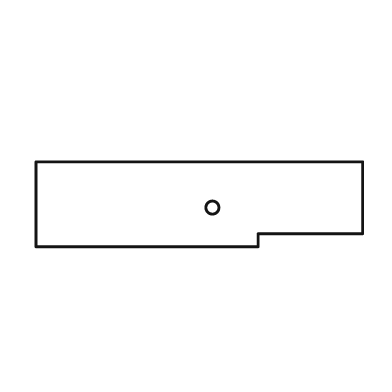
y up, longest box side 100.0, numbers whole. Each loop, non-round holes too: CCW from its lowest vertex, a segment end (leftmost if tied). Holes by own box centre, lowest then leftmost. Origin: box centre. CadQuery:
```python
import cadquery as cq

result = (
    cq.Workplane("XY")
    .moveTo(-50.0, -13.0)
    .lineTo(18.0, -13.0)
    .lineTo(18.0, -9.0)
    .lineTo(50.0, -9.0)
    .lineTo(50.0, 13.0)
    .lineTo(-50.0, 13.0)
    .close()
    .moveTo(4.0, -1.0)
    .circle(2.0)
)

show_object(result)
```